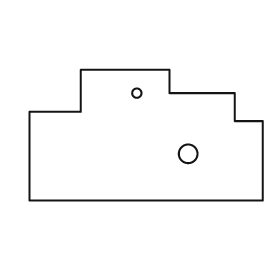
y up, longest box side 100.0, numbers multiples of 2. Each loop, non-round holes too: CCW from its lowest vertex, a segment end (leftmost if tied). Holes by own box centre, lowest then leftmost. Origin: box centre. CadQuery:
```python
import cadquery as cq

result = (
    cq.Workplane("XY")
    .moveTo(-50.0, -28.0)
    .lineTo(50.0, -28.0)
    .lineTo(50.0, 6.0)
    .lineTo(38.0, 6.0)
    .lineTo(38.0, 18.0)
    .lineTo(10.0, 18.0)
    .lineTo(10.0, 28.0)
    .lineTo(-28.0, 28.0)
    .lineTo(-28.0, 10.0)
    .lineTo(-50.0, 10.0)
    .close()
    .moveTo(18.0, -8.0)
    .circle(4.0)
    .moveTo(-4.0, 18.0)
    .circle(2.0)
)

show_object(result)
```